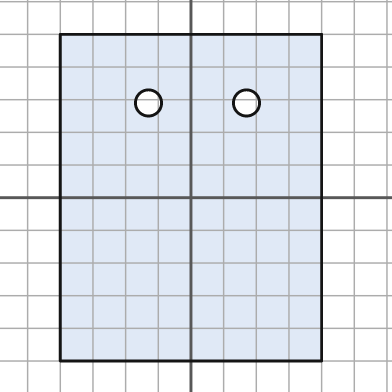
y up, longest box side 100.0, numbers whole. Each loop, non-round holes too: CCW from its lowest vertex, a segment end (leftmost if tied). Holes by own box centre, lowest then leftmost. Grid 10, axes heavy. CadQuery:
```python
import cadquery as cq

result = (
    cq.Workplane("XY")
    .moveTo(-40.0, -50.0)
    .lineTo(40.0, -50.0)
    .lineTo(40.0, 50.0)
    .lineTo(-40.0, 50.0)
    .close()
    .moveTo(-13.0, 29.0)
    .circle(4.0)
    .moveTo(17.0, 29.0)
    .circle(4.0)
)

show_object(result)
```